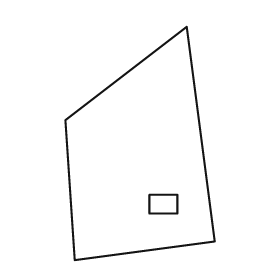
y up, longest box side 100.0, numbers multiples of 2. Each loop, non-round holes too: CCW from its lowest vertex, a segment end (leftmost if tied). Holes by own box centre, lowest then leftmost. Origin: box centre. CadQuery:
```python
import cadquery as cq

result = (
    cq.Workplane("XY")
    .moveTo(-28.0, -50.0)
    .lineTo(32.0, -42.0)
    .lineTo(20.0, 50.0)
    .lineTo(-32.0, 10.0)
    .close()
    .moveTo(4.0, -30.0)
    .lineTo(16.0, -30.0)
    .lineTo(16.0, -22.0)
    .lineTo(4.0, -22.0)
    .close()
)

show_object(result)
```